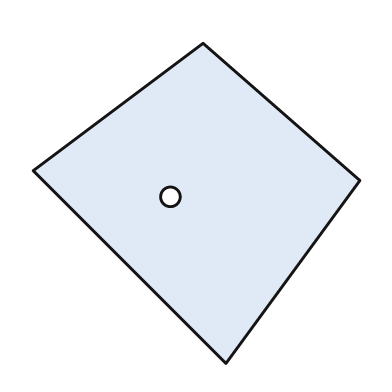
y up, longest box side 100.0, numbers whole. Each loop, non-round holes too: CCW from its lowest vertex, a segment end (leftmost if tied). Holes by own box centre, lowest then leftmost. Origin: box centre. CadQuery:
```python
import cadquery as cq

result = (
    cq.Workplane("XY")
    .moveTo(9.0, -49.0)
    .lineTo(50.0, 7.0)
    .lineTo(2.0, 49.0)
    .lineTo(-50.0, 10.0)
    .close()
    .moveTo(-8.0, 2.0)
    .circle(3.0)
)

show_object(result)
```